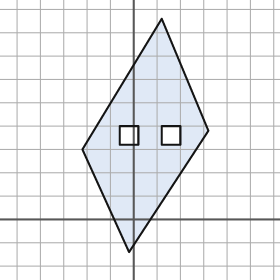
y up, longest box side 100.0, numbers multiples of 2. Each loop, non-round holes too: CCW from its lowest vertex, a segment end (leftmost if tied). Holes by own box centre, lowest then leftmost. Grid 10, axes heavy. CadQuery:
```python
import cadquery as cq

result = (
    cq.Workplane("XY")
    .moveTo(-2.0, -14.0)
    .lineTo(32.0, 38.0)
    .lineTo(12.0, 86.0)
    .lineTo(-22.0, 30.0)
    .close()
    .moveTo(-6.0, 32.0)
    .lineTo(2.0, 32.0)
    .lineTo(2.0, 40.0)
    .lineTo(-6.0, 40.0)
    .close()
    .moveTo(12.0, 32.0)
    .lineTo(20.0, 32.0)
    .lineTo(20.0, 40.0)
    .lineTo(12.0, 40.0)
    .close()
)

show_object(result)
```